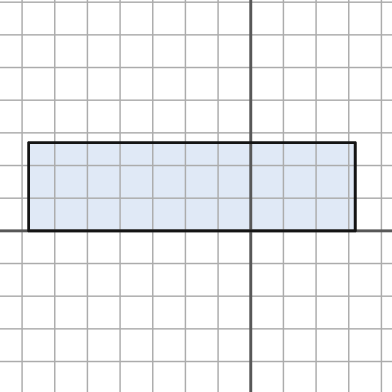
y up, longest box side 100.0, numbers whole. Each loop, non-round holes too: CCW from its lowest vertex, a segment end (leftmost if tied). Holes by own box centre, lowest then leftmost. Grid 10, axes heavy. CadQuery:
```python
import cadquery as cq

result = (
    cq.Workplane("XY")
    .moveTo(-68.0, 0.0)
    .lineTo(32.0, 0.0)
    .lineTo(32.0, 27.0)
    .lineTo(-68.0, 27.0)
    .close()
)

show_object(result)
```